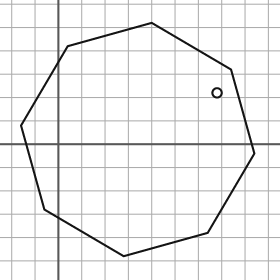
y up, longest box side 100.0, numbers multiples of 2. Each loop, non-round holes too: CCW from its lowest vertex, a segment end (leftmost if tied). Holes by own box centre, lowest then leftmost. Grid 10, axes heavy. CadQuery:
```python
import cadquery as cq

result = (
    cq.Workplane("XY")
    .moveTo(28.0, -48.0)
    .lineTo(64.0, -38.0)
    .lineTo(84.0, -4.0)
    .lineTo(74.0, 32.0)
    .lineTo(40.0, 52.0)
    .lineTo(4.0, 42.0)
    .lineTo(-16.0, 8.0)
    .lineTo(-6.0, -28.0)
    .close()
    .moveTo(68.0, 22.0)
    .circle(2.0)
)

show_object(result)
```